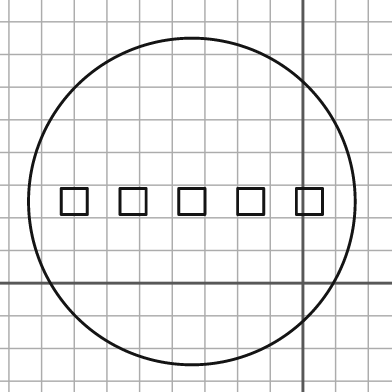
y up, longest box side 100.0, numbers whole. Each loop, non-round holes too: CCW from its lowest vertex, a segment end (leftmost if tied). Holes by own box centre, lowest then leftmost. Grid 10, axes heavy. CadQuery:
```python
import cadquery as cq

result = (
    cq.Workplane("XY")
    .moveTo(-34.0, 25.0)
    .circle(50.0)
    .moveTo(-74.0, 21.0)
    .lineTo(-66.0, 21.0)
    .lineTo(-66.0, 29.0)
    .lineTo(-74.0, 29.0)
    .close()
    .moveTo(-56.0, 21.0)
    .lineTo(-48.0, 21.0)
    .lineTo(-48.0, 29.0)
    .lineTo(-56.0, 29.0)
    .close()
    .moveTo(-38.0, 21.0)
    .lineTo(-30.0, 21.0)
    .lineTo(-30.0, 29.0)
    .lineTo(-38.0, 29.0)
    .close()
    .moveTo(-20.0, 21.0)
    .lineTo(-12.0, 21.0)
    .lineTo(-12.0, 29.0)
    .lineTo(-20.0, 29.0)
    .close()
    .moveTo(-2.0, 21.0)
    .lineTo(6.0, 21.0)
    .lineTo(6.0, 29.0)
    .lineTo(-2.0, 29.0)
    .close()
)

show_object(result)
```